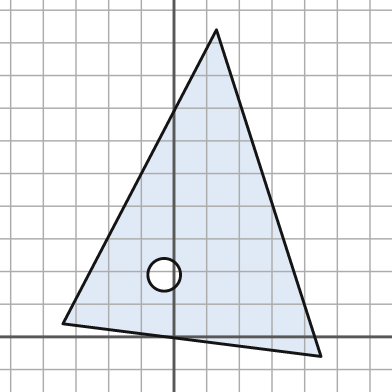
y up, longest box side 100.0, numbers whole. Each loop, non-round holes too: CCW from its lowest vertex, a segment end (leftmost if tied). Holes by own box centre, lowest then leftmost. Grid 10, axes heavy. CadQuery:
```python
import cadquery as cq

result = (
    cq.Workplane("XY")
    .moveTo(45.0, -6.0)
    .lineTo(13.0, 94.0)
    .lineTo(-34.0, 4.0)
    .close()
    .moveTo(-3.0, 19.0)
    .circle(5.0)
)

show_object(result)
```